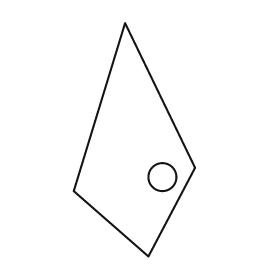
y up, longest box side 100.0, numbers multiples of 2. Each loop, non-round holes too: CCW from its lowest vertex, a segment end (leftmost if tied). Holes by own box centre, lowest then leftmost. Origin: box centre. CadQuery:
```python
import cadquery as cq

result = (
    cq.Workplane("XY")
    .moveTo(6.0, -50.0)
    .lineTo(26.0, -12.0)
    .lineTo(-4.0, 50.0)
    .lineTo(-26.0, -22.0)
    .close()
    .moveTo(12.0, -16.0)
    .circle(6.0)
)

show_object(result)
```